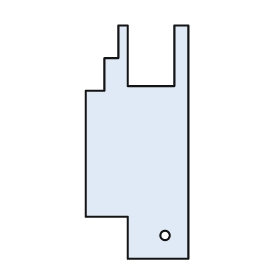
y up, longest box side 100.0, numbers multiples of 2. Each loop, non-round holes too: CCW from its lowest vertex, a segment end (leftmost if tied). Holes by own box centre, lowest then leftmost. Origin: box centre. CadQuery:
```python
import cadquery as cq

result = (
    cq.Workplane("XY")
    .moveTo(-4.0, -50.0)
    .lineTo(22.0, -50.0)
    .lineTo(22.0, 50.0)
    .lineTo(16.0, 50.0)
    .lineTo(16.0, 24.0)
    .lineTo(-4.0, 24.0)
    .lineTo(-4.0, 50.0)
    .lineTo(-8.0, 50.0)
    .lineTo(-8.0, 36.0)
    .lineTo(-14.0, 36.0)
    .lineTo(-14.0, 22.0)
    .lineTo(-22.0, 22.0)
    .lineTo(-22.0, -32.0)
    .lineTo(-4.0, -32.0)
    .close()
    .moveTo(12.0, -40.0)
    .circle(2.0)
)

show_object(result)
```